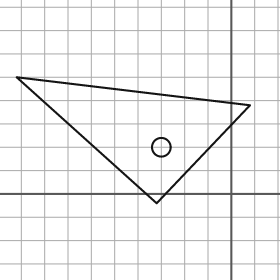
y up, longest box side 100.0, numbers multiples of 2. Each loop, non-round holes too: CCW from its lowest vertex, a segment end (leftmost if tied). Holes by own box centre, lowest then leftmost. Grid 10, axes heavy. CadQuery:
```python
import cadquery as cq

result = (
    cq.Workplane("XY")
    .moveTo(-32.0, -4.0)
    .lineTo(8.0, 38.0)
    .lineTo(-92.0, 50.0)
    .close()
    .moveTo(-30.0, 20.0)
    .circle(4.0)
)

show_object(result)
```